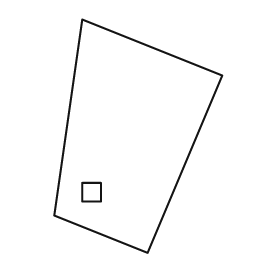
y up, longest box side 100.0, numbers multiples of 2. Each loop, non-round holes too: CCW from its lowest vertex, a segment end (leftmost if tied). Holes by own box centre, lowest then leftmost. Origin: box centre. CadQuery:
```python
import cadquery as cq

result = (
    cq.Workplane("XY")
    .moveTo(4.0, -50.0)
    .lineTo(36.0, 26.0)
    .lineTo(-24.0, 50.0)
    .lineTo(-36.0, -34.0)
    .close()
    .moveTo(-24.0, -28.0)
    .lineTo(-16.0, -28.0)
    .lineTo(-16.0, -20.0)
    .lineTo(-24.0, -20.0)
    .close()
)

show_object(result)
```